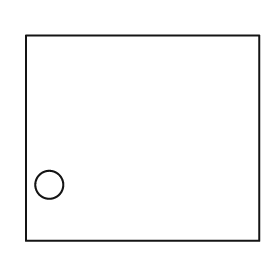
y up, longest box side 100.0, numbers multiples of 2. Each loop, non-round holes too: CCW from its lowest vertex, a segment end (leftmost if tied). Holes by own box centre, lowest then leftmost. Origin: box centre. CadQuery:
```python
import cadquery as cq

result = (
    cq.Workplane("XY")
    .moveTo(-50.0, -44.0)
    .lineTo(50.0, -44.0)
    .lineTo(50.0, 44.0)
    .lineTo(-50.0, 44.0)
    .close()
    .moveTo(-40.0, -20.0)
    .circle(6.0)
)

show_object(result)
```